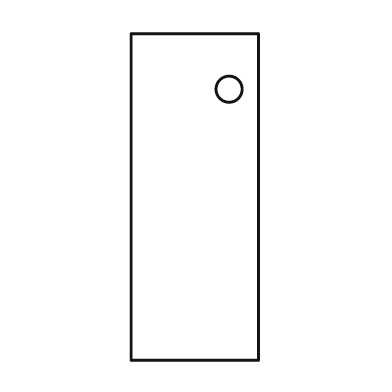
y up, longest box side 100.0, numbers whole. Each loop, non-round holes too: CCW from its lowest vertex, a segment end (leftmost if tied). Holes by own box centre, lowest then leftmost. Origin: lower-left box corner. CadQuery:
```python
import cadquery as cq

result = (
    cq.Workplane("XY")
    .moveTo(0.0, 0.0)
    .lineTo(39.0, 0.0)
    .lineTo(39.0, 100.0)
    .lineTo(0.0, 100.0)
    .close()
    .moveTo(30.0, 83.0)
    .circle(4.0)
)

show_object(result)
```